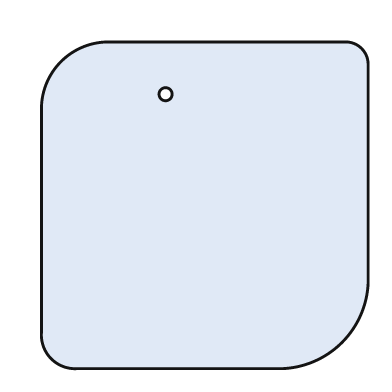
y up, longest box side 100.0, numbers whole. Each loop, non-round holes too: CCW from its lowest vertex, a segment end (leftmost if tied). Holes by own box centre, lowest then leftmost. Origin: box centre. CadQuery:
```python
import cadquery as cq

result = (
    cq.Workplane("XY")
    .moveTo(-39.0, -50.0)
    .lineTo(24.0, -50.0)
    .threePointArc((42.0, -42.0), (50.0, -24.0))
    .lineTo(50.0, 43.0)
    .threePointArc((48.0, 48.0), (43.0, 50.0))
    .lineTo(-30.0, 50.0)
    .threePointArc((-44.0, 44.0), (-50.0, 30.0))
    .lineTo(-50.0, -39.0)
    .threePointArc((-47.0, -47.0), (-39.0, -50.0))
    .close()
    .moveTo(-12.0, 34.0)
    .circle(2.0)
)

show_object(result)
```